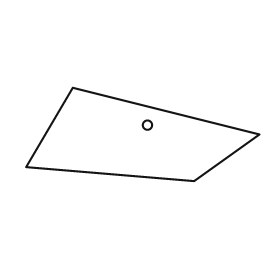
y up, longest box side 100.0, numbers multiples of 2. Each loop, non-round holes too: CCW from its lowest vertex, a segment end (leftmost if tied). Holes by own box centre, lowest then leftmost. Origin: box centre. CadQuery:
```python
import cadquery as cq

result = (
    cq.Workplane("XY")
    .moveTo(22.0, -20.0)
    .lineTo(50.0, 0.0)
    .lineTo(-30.0, 20.0)
    .lineTo(-50.0, -14.0)
    .close()
    .moveTo(2.0, 4.0)
    .circle(2.0)
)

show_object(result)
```